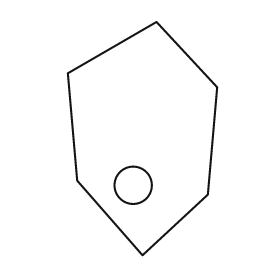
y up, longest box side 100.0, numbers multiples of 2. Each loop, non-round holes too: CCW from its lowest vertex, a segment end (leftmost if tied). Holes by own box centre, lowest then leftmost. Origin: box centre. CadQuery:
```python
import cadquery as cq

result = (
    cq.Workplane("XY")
    .moveTo(0.0, -50.0)
    .lineTo(28.0, -24.0)
    .lineTo(32.0, 22.0)
    .lineTo(6.0, 50.0)
    .lineTo(-32.0, 28.0)
    .lineTo(-28.0, -18.0)
    .close()
    .moveTo(-4.0, -20.0)
    .circle(8.0)
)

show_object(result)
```